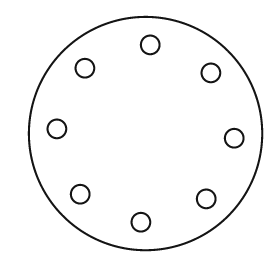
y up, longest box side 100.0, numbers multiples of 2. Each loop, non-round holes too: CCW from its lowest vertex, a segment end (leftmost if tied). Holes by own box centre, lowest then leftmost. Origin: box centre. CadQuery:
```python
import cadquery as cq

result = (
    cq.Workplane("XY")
    .moveTo(0.0, 0.0)
    .circle(50.0)
    .moveTo(-2.0, -38.0)
    .circle(4.0)
    .moveTo(26.0, -28.0)
    .circle(4.0)
    .moveTo(-28.0, -26.0)
    .circle(4.0)
    .moveTo(38.0, -2.0)
    .circle(4.0)
    .moveTo(-38.0, 2.0)
    .circle(4.0)
    .moveTo(28.0, 26.0)
    .circle(4.0)
    .moveTo(-26.0, 28.0)
    .circle(4.0)
    .moveTo(2.0, 38.0)
    .circle(4.0)
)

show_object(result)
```